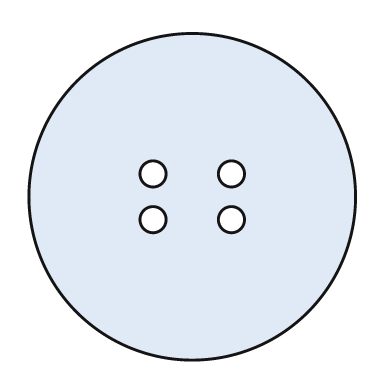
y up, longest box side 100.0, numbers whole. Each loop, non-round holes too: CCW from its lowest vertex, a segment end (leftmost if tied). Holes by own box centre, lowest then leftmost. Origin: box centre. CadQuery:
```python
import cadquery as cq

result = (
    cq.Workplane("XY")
    .moveTo(0.0, 0.0)
    .circle(50.0)
    .moveTo(-12.0, -7.0)
    .circle(4.0)
    .moveTo(12.0, -7.0)
    .circle(4.0)
    .moveTo(-12.0, 7.0)
    .circle(4.0)
    .moveTo(12.0, 7.0)
    .circle(4.0)
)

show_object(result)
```